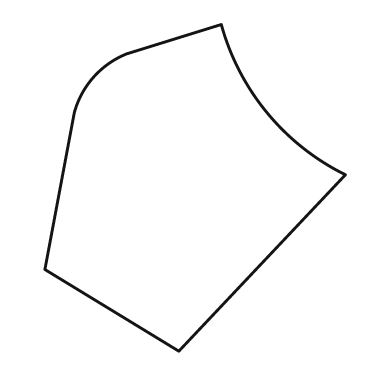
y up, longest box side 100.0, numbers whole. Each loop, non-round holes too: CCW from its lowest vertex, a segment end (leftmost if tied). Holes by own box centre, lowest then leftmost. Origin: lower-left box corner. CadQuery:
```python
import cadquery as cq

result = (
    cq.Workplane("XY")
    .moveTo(41.0, 0.0)
    .lineTo(92.0, 54.0)
    .threePointArc((68.0, 73.0), (54.0, 100.0))
    .lineTo(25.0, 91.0)
    .threePointArc((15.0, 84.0), (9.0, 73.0))
    .lineTo(0.0, 25.0)
    .close()
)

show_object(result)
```